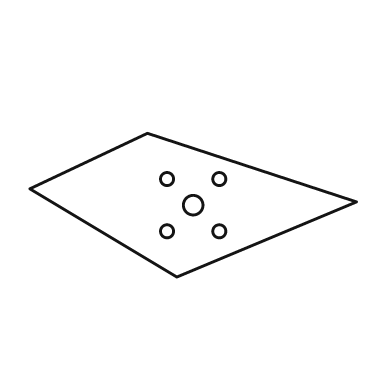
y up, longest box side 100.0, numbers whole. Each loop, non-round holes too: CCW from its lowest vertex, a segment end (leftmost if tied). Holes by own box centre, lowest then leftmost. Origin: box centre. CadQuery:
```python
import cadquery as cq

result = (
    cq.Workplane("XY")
    .moveTo(-5.0, -22.0)
    .lineTo(50.0, 1.0)
    .lineTo(-14.0, 22.0)
    .lineTo(-50.0, 5.0)
    .close()
    .moveTo(-8.0, -8.0)
    .circle(2.0)
    .moveTo(8.0, -8.0)
    .circle(2.0)
    .moveTo(0.0, 0.0)
    .circle(3.0)
    .moveTo(-8.0, 8.0)
    .circle(2.0)
    .moveTo(8.0, 8.0)
    .circle(2.0)
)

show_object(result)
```